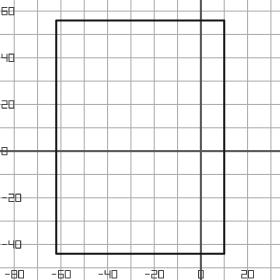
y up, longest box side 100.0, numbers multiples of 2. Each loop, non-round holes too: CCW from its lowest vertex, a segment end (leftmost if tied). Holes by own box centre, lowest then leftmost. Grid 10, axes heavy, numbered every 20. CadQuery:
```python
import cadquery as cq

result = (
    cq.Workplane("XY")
    .moveTo(-62.0, -44.0)
    .lineTo(10.0, -44.0)
    .lineTo(10.0, 56.0)
    .lineTo(-62.0, 56.0)
    .close()
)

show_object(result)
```